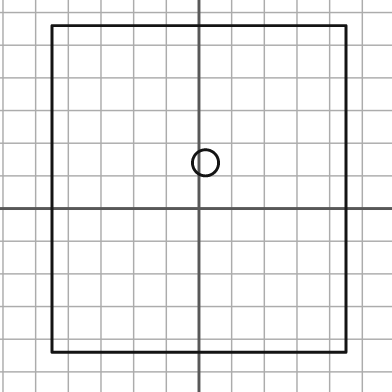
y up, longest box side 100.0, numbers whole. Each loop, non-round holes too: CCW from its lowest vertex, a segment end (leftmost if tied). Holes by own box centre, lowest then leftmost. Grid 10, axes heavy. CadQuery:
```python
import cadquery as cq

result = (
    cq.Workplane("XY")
    .moveTo(-45.0, -44.0)
    .lineTo(45.0, -44.0)
    .lineTo(45.0, 56.0)
    .lineTo(-45.0, 56.0)
    .close()
    .moveTo(2.0, 14.0)
    .circle(4.0)
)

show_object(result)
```